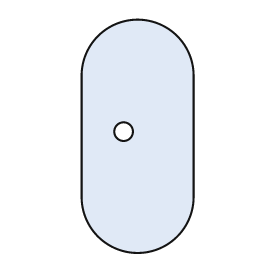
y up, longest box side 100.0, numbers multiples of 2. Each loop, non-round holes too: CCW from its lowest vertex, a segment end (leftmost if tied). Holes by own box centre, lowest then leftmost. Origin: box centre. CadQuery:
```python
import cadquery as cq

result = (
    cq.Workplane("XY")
    .moveTo(-24.0, -26.0)
    .threePointArc((0.0, -50.0), (24.0, -26.0))
    .lineTo(24.0, 26.0)
    .threePointArc((0.0, 50.0), (-24.0, 26.0))
    .close()
    .moveTo(-6.0, 2.0)
    .circle(4.0)
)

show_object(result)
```